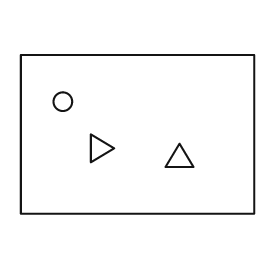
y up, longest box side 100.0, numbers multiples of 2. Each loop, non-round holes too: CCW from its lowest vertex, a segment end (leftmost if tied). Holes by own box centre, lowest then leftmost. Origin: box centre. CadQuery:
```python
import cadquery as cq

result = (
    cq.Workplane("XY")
    .moveTo(-50.0, -34.0)
    .lineTo(50.0, -34.0)
    .lineTo(50.0, 34.0)
    .lineTo(-50.0, 34.0)
    .close()
    .moveTo(12.0, -14.0)
    .lineTo(24.0, -14.0)
    .lineTo(18.0, -4.0)
    .close()
    .moveTo(-20.0, -12.0)
    .lineTo(-10.0, -6.0)
    .lineTo(-20.0, 0.0)
    .close()
    .moveTo(-32.0, 14.0)
    .circle(4.0)
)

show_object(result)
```